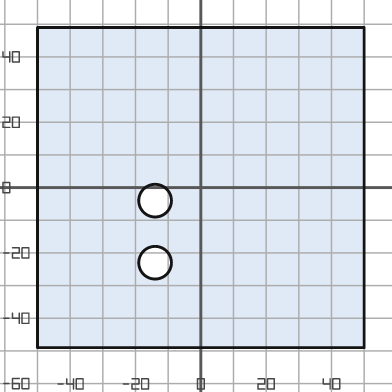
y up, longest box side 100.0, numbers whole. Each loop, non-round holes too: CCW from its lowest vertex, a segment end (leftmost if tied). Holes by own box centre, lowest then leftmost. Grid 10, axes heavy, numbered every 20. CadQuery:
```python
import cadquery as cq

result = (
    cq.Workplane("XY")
    .moveTo(-50.0, -49.0)
    .lineTo(50.0, -49.0)
    .lineTo(50.0, 49.0)
    .lineTo(-50.0, 49.0)
    .close()
    .moveTo(-14.0, -23.0)
    .circle(5.0)
    .moveTo(-14.0, -4.0)
    .circle(5.0)
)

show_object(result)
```